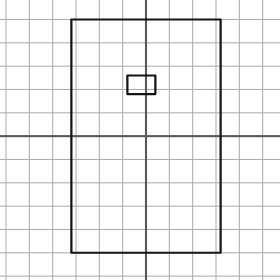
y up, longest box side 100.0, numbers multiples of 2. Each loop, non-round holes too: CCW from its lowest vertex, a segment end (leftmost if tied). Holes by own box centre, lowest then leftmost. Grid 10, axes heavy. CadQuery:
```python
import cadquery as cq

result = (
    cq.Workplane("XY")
    .moveTo(-32.0, -50.0)
    .lineTo(32.0, -50.0)
    .lineTo(32.0, 50.0)
    .lineTo(-32.0, 50.0)
    .close()
    .moveTo(-8.0, 18.0)
    .lineTo(4.0, 18.0)
    .lineTo(4.0, 26.0)
    .lineTo(-8.0, 26.0)
    .close()
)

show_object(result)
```